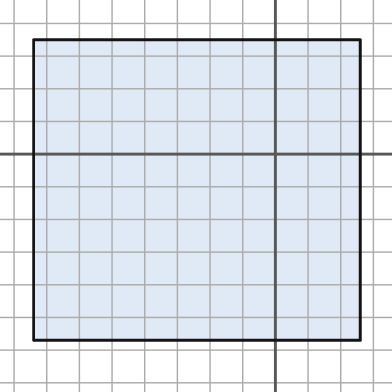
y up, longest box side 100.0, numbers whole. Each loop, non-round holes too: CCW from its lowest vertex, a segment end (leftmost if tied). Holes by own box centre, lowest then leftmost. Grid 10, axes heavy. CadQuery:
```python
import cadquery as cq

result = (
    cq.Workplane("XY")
    .moveTo(-74.0, -57.0)
    .lineTo(26.0, -57.0)
    .lineTo(26.0, 35.0)
    .lineTo(-74.0, 35.0)
    .close()
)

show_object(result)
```